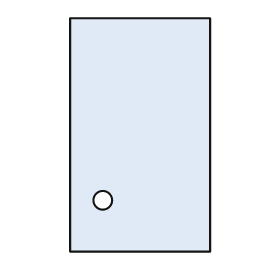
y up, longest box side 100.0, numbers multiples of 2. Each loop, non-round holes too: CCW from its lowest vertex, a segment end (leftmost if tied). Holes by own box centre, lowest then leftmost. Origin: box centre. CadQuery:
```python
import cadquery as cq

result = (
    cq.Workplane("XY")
    .moveTo(-30.0, -50.0)
    .lineTo(30.0, -50.0)
    .lineTo(30.0, 50.0)
    .lineTo(-30.0, 50.0)
    .close()
    .moveTo(-16.0, -28.0)
    .circle(4.0)
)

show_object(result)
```